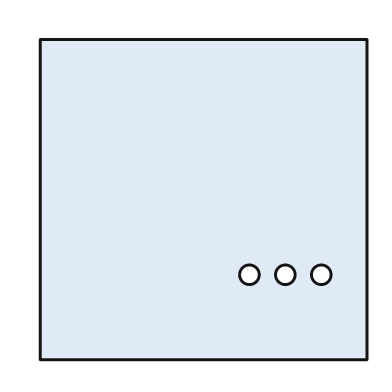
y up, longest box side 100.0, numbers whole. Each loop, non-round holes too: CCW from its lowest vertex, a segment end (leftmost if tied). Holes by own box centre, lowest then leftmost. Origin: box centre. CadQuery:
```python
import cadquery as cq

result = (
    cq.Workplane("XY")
    .moveTo(-50.0, -49.0)
    .lineTo(50.0, -49.0)
    .lineTo(50.0, 49.0)
    .lineTo(-50.0, 49.0)
    .close()
    .moveTo(14.0, -23.0)
    .circle(3.0)
    .moveTo(25.0, -23.0)
    .circle(3.0)
    .moveTo(36.0, -23.0)
    .circle(3.0)
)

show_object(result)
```